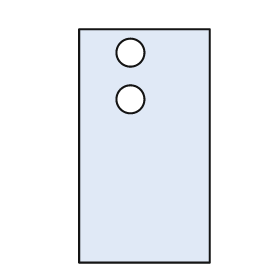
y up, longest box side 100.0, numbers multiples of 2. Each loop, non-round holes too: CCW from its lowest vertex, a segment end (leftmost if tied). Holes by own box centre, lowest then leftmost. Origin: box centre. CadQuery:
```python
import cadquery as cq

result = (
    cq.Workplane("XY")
    .moveTo(-28.0, -50.0)
    .lineTo(28.0, -50.0)
    .lineTo(28.0, 50.0)
    .lineTo(-28.0, 50.0)
    .close()
    .moveTo(-6.0, 20.0)
    .circle(6.0)
    .moveTo(-6.0, 40.0)
    .circle(6.0)
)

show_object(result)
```